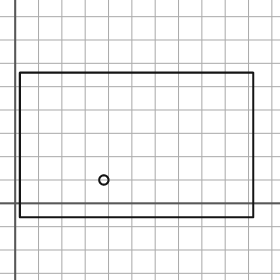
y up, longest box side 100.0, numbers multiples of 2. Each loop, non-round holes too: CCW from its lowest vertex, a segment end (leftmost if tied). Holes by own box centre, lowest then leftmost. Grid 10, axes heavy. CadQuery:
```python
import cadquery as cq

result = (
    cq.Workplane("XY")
    .moveTo(2.0, -6.0)
    .lineTo(102.0, -6.0)
    .lineTo(102.0, 56.0)
    .lineTo(2.0, 56.0)
    .close()
    .moveTo(38.0, 10.0)
    .circle(2.0)
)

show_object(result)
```